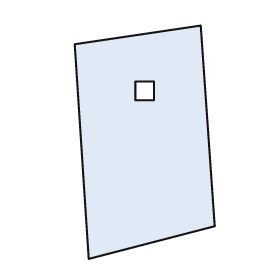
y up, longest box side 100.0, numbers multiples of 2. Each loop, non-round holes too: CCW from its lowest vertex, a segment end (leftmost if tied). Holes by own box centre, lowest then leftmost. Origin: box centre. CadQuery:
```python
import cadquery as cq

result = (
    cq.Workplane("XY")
    .moveTo(-24.0, -50.0)
    .lineTo(30.0, -36.0)
    .lineTo(24.0, 50.0)
    .lineTo(-30.0, 42.0)
    .close()
    .moveTo(-4.0, 18.0)
    .lineTo(4.0, 18.0)
    .lineTo(4.0, 26.0)
    .lineTo(-4.0, 26.0)
    .close()
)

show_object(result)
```